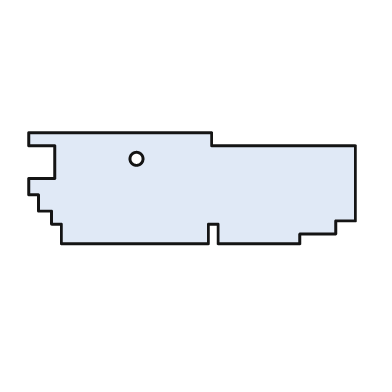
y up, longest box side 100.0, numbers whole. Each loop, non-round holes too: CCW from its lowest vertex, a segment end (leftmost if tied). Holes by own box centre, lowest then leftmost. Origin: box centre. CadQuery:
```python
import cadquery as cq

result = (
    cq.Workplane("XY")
    .moveTo(-40.0, -17.0)
    .lineTo(5.0, -17.0)
    .lineTo(5.0, -11.0)
    .lineTo(8.0, -11.0)
    .lineTo(8.0, -17.0)
    .lineTo(33.0, -17.0)
    .lineTo(33.0, -14.0)
    .lineTo(44.0, -14.0)
    .lineTo(44.0, -10.0)
    .lineTo(50.0, -10.0)
    .lineTo(50.0, 13.0)
    .lineTo(6.0, 13.0)
    .lineTo(6.0, 17.0)
    .lineTo(-50.0, 17.0)
    .lineTo(-50.0, 13.0)
    .lineTo(-42.0, 13.0)
    .lineTo(-42.0, 3.0)
    .lineTo(-50.0, 3.0)
    .lineTo(-50.0, -2.0)
    .lineTo(-47.0, -2.0)
    .lineTo(-47.0, -7.0)
    .lineTo(-43.0, -7.0)
    .lineTo(-43.0, -11.0)
    .lineTo(-40.0, -11.0)
    .close()
    .moveTo(-17.0, 9.0)
    .circle(2.0)
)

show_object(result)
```